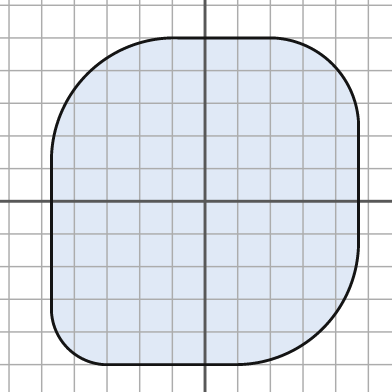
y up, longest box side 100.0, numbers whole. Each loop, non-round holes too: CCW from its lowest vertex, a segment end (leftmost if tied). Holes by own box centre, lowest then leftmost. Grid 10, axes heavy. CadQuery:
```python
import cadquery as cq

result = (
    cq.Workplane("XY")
    .moveTo(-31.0, -50.0)
    .lineTo(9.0, -50.0)
    .threePointArc((36.0, -39.0), (47.0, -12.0))
    .lineTo(47.0, 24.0)
    .threePointArc((39.0, 42.0), (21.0, 50.0))
    .lineTo(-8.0, 50.0)
    .threePointArc((-36.0, 39.0), (-47.0, 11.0))
    .lineTo(-47.0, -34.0)
    .threePointArc((-42.0, -45.0), (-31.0, -50.0))
    .close()
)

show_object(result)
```